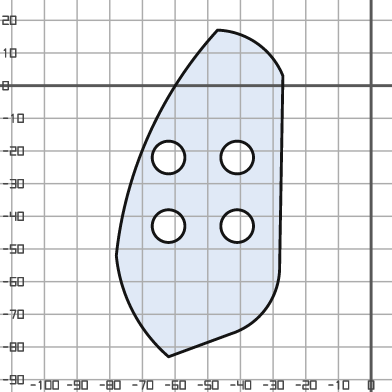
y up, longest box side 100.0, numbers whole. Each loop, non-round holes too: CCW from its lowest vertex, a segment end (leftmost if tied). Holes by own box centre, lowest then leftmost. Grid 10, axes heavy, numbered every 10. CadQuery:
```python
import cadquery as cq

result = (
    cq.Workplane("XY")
    .moveTo(-62.0, -83.0)
    .lineTo(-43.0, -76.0)
    .threePointArc((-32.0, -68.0), (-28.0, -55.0))
    .lineTo(-27.0, 3.0)
    .threePointArc((-35.0, 13.0), (-47.0, 17.0))
    .threePointArc((-68.0, -15.0), (-78.0, -52.0))
    .threePointArc((-73.0, -69.0), (-62.0, -83.0))
    .close()
    .moveTo(-62.0, -43.0)
    .circle(5.0)
    .moveTo(-41.0, -43.0)
    .circle(5.0)
    .moveTo(-62.0, -22.0)
    .circle(5.0)
    .moveTo(-41.0, -22.0)
    .circle(5.0)
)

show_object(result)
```